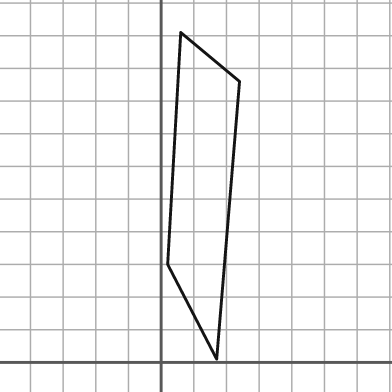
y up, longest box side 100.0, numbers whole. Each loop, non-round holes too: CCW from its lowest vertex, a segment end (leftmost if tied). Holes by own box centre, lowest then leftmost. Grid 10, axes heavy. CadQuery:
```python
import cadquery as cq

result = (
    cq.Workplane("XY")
    .moveTo(17.0, 1.0)
    .lineTo(24.0, 86.0)
    .lineTo(6.0, 101.0)
    .lineTo(2.0, 30.0)
    .close()
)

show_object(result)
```